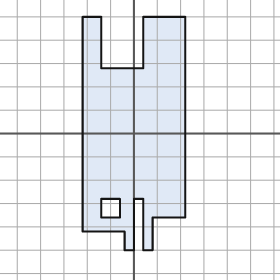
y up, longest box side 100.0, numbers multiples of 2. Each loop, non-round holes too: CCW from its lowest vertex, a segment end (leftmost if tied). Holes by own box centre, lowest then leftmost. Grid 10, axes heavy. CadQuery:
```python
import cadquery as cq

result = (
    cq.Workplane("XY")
    .moveTo(-4.0, -50.0)
    .lineTo(0.0, -50.0)
    .lineTo(0.0, -28.0)
    .lineTo(4.0, -28.0)
    .lineTo(4.0, -50.0)
    .lineTo(8.0, -50.0)
    .lineTo(8.0, -36.0)
    .lineTo(22.0, -36.0)
    .lineTo(22.0, 50.0)
    .lineTo(4.0, 50.0)
    .lineTo(4.0, 28.0)
    .lineTo(-14.0, 28.0)
    .lineTo(-14.0, 50.0)
    .lineTo(-22.0, 50.0)
    .lineTo(-22.0, -42.0)
    .lineTo(-4.0, -42.0)
    .close()
    .moveTo(-14.0, -36.0)
    .lineTo(-6.0, -36.0)
    .lineTo(-6.0, -28.0)
    .lineTo(-14.0, -28.0)
    .close()
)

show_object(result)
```